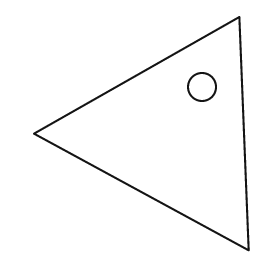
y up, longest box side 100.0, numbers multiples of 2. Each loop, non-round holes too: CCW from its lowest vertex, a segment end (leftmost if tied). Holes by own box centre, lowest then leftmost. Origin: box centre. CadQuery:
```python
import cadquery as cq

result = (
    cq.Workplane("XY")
    .moveTo(46.0, -50.0)
    .lineTo(42.0, 50.0)
    .lineTo(-46.0, 0.0)
    .close()
    .moveTo(26.0, 20.0)
    .circle(6.0)
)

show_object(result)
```